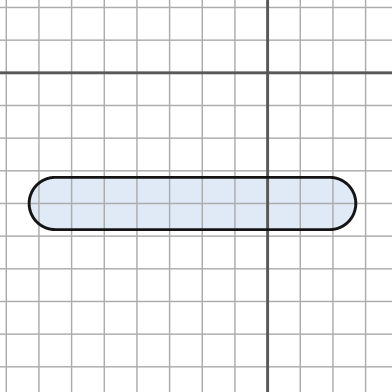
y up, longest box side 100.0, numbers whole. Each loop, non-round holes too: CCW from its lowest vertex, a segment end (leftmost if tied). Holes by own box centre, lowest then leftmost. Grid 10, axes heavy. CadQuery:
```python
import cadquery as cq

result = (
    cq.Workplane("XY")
    .moveTo(-65.0, -48.0)
    .lineTo(19.0, -48.0)
    .threePointArc((27.0, -40.0), (19.0, -32.0))
    .lineTo(-65.0, -32.0)
    .threePointArc((-73.0, -40.0), (-65.0, -48.0))
    .close()
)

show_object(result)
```